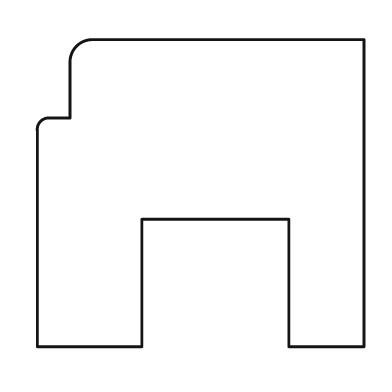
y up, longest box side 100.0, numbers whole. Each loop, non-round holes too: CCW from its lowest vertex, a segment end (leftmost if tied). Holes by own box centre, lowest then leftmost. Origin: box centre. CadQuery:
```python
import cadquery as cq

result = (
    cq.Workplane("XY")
    .moveTo(-50.0, -47.0)
    .lineTo(-18.0, -47.0)
    .lineTo(-18.0, -8.0)
    .lineTo(27.0, -8.0)
    .lineTo(27.0, -47.0)
    .lineTo(50.0, -47.0)
    .lineTo(50.0, 47.0)
    .lineTo(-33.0, 47.0)
    .threePointArc((-38.0, 45.0), (-40.0, 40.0))
    .lineTo(-40.0, 23.0)
    .lineTo(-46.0, 23.0)
    .threePointArc((-49.0, 22.0), (-50.0, 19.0))
    .close()
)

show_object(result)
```